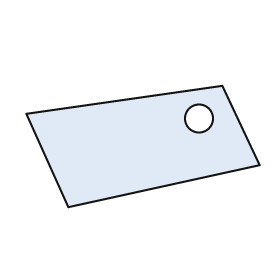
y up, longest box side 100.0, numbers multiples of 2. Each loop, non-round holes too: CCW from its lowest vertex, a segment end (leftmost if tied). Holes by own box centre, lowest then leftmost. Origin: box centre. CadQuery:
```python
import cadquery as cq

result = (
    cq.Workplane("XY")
    .moveTo(-32.0, -26.0)
    .lineTo(50.0, -8.0)
    .lineTo(34.0, 26.0)
    .lineTo(-50.0, 14.0)
    .close()
    .moveTo(24.0, 12.0)
    .circle(6.0)
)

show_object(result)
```